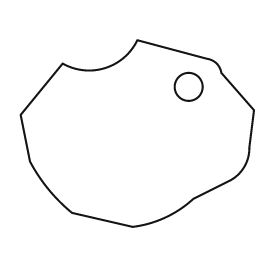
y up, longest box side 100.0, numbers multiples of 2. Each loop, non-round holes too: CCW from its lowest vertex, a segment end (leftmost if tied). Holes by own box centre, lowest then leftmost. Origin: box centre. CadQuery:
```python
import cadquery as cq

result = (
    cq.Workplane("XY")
    .moveTo(-2.0, -40.0)
    .threePointArc((12.0, -36.0), (24.0, -28.0))
    .lineTo(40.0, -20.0)
    .threePointArc((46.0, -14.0), (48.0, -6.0))
    .lineTo(50.0, 10.0)
    .lineTo(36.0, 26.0)
    .threePointArc((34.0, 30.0), (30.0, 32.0))
    .lineTo(0.0, 40.0)
    .threePointArc((-14.0, 28.0), (-32.0, 30.0))
    .lineTo(-50.0, 8.0)
    .lineTo(-46.0, -12.0)
    .threePointArc((-38.0, -24.0), (-28.0, -34.0))
    .close()
    .moveTo(22.0, 20.0)
    .circle(6.0)
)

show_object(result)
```